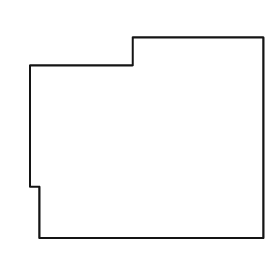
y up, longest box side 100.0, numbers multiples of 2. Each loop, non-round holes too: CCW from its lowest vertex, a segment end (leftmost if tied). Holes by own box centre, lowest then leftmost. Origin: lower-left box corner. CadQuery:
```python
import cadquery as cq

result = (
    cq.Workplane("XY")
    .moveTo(4.0, 0.0)
    .lineTo(100.0, 0.0)
    .lineTo(100.0, 86.0)
    .lineTo(44.0, 86.0)
    .lineTo(44.0, 74.0)
    .lineTo(0.0, 74.0)
    .lineTo(0.0, 22.0)
    .lineTo(4.0, 22.0)
    .close()
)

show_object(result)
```